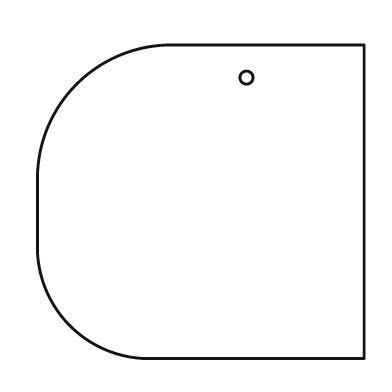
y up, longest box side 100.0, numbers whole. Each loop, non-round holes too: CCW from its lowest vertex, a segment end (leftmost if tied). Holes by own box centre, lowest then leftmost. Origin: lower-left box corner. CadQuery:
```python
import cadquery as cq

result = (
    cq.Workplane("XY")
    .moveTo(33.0, 0.0)
    .lineTo(100.0, 0.0)
    .lineTo(100.0, 96.0)
    .lineTo(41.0, 96.0)
    .threePointArc((12.0, 84.0), (0.0, 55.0))
    .lineTo(0.0, 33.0)
    .threePointArc((10.0, 10.0), (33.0, 0.0))
    .close()
    .moveTo(64.0, 86.0)
    .circle(2.0)
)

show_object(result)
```